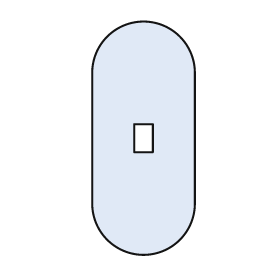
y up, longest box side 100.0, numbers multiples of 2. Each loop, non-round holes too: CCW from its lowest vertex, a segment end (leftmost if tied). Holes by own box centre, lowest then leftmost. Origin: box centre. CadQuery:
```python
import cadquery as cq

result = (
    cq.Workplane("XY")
    .moveTo(-22.0, -28.0)
    .threePointArc((0.0, -50.0), (22.0, -28.0))
    .lineTo(22.0, 28.0)
    .threePointArc((0.0, 50.0), (-22.0, 28.0))
    .close()
    .moveTo(-4.0, -6.0)
    .lineTo(4.0, -6.0)
    .lineTo(4.0, 6.0)
    .lineTo(-4.0, 6.0)
    .close()
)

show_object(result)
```